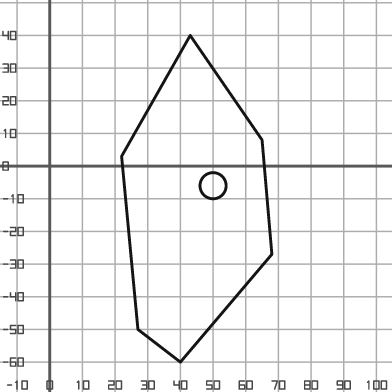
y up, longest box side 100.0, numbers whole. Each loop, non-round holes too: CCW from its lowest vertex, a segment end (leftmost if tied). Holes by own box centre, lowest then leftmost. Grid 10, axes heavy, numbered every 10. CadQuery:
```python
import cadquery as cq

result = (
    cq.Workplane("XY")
    .moveTo(40.0, -60.0)
    .lineTo(68.0, -27.0)
    .lineTo(65.0, 8.0)
    .lineTo(43.0, 40.0)
    .lineTo(22.0, 3.0)
    .lineTo(27.0, -50.0)
    .close()
    .moveTo(50.0, -6.0)
    .circle(4.0)
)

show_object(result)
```